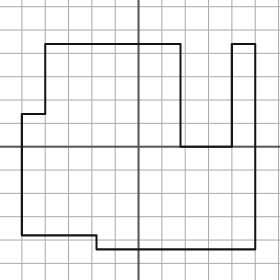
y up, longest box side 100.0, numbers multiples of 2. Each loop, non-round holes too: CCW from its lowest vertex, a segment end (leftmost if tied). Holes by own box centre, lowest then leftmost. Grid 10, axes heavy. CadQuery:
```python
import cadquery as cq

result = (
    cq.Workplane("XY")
    .moveTo(-18.0, -44.0)
    .lineTo(50.0, -44.0)
    .lineTo(50.0, 44.0)
    .lineTo(40.0, 44.0)
    .lineTo(40.0, 0.0)
    .lineTo(18.0, 0.0)
    .lineTo(18.0, 44.0)
    .lineTo(-40.0, 44.0)
    .lineTo(-40.0, 14.0)
    .lineTo(-50.0, 14.0)
    .lineTo(-50.0, -38.0)
    .lineTo(-18.0, -38.0)
    .close()
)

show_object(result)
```